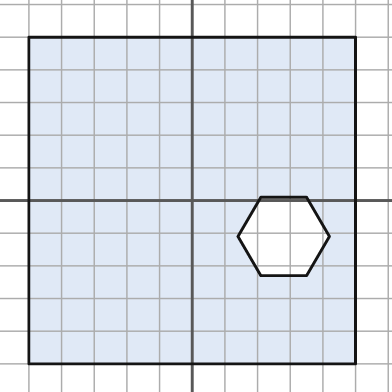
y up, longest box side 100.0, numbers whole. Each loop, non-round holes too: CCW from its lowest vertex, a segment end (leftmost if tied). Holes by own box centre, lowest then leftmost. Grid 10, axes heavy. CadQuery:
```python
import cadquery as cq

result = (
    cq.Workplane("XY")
    .moveTo(-50.0, -50.0)
    .lineTo(50.0, -50.0)
    .lineTo(50.0, 50.0)
    .lineTo(-50.0, 50.0)
    .close()
    .moveTo(21.0, -23.0)
    .lineTo(35.0, -23.0)
    .lineTo(42.0, -11.0)
    .lineTo(35.0, 1.0)
    .lineTo(21.0, 1.0)
    .lineTo(14.0, -11.0)
    .close()
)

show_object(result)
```